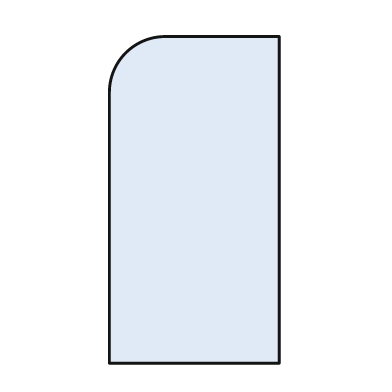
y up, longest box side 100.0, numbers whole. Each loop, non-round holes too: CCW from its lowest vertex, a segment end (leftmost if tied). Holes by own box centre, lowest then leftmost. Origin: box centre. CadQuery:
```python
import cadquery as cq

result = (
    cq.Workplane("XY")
    .moveTo(-26.0, -50.0)
    .lineTo(26.0, -50.0)
    .lineTo(26.0, 50.0)
    .lineTo(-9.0, 50.0)
    .threePointArc((-21.0, 45.0), (-26.0, 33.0))
    .close()
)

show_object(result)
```